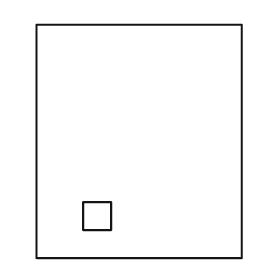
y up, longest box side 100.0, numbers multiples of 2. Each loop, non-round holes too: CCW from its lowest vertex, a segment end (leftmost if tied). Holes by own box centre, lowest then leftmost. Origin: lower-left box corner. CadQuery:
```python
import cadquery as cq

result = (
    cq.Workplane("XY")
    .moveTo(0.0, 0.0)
    .lineTo(88.0, 0.0)
    .lineTo(88.0, 100.0)
    .lineTo(0.0, 100.0)
    .close()
    .moveTo(20.0, 12.0)
    .lineTo(32.0, 12.0)
    .lineTo(32.0, 24.0)
    .lineTo(20.0, 24.0)
    .close()
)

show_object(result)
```